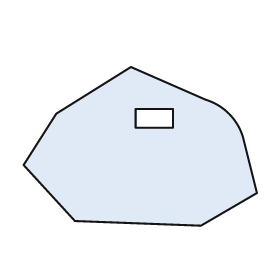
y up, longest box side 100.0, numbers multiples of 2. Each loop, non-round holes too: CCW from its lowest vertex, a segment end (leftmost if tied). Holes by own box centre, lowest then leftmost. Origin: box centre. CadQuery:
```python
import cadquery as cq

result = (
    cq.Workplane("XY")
    .moveTo(26.0, -34.0)
    .lineTo(50.0, -20.0)
    .lineTo(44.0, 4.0)
    .threePointArc((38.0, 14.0), (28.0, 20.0))
    .lineTo(-4.0, 34.0)
    .lineTo(-36.0, 14.0)
    .lineTo(-50.0, -8.0)
    .lineTo(-28.0, -32.0)
    .close()
    .moveTo(-2.0, 8.0)
    .lineTo(14.0, 8.0)
    .lineTo(14.0, 16.0)
    .lineTo(-2.0, 16.0)
    .close()
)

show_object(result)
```